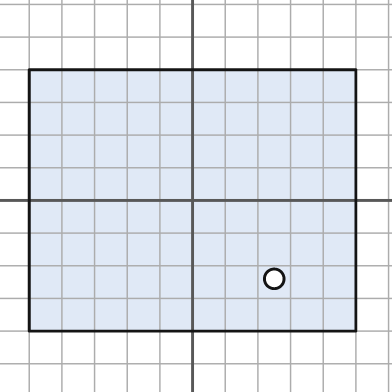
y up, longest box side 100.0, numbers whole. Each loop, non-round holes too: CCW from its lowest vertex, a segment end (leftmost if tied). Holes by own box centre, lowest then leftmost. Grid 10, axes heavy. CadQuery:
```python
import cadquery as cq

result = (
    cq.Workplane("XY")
    .moveTo(-50.0, -40.0)
    .lineTo(50.0, -40.0)
    .lineTo(50.0, 40.0)
    .lineTo(-50.0, 40.0)
    .close()
    .moveTo(25.0, -24.0)
    .circle(3.0)
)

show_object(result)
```